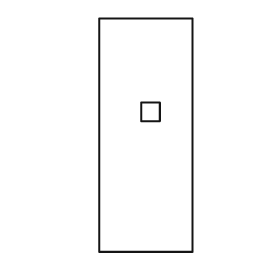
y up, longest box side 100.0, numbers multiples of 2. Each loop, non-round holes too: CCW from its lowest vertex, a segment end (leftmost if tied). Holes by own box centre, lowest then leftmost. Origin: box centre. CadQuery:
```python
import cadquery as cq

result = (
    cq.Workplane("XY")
    .moveTo(-20.0, -50.0)
    .lineTo(20.0, -50.0)
    .lineTo(20.0, 50.0)
    .lineTo(-20.0, 50.0)
    .close()
    .moveTo(-2.0, 6.0)
    .lineTo(6.0, 6.0)
    .lineTo(6.0, 14.0)
    .lineTo(-2.0, 14.0)
    .close()
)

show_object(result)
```